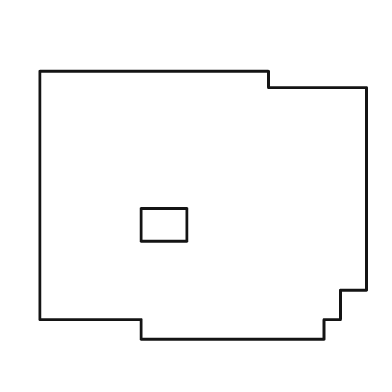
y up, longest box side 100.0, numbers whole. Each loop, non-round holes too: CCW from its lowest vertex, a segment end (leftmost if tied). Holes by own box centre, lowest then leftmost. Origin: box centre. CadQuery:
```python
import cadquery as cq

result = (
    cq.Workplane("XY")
    .moveTo(-19.0, -41.0)
    .lineTo(37.0, -41.0)
    .lineTo(37.0, -35.0)
    .lineTo(42.0, -35.0)
    .lineTo(42.0, -26.0)
    .lineTo(50.0, -26.0)
    .lineTo(50.0, 36.0)
    .lineTo(20.0, 36.0)
    .lineTo(20.0, 41.0)
    .lineTo(-50.0, 41.0)
    .lineTo(-50.0, -35.0)
    .lineTo(-19.0, -35.0)
    .close()
    .moveTo(-19.0, -11.0)
    .lineTo(-5.0, -11.0)
    .lineTo(-5.0, -1.0)
    .lineTo(-19.0, -1.0)
    .close()
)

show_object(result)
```